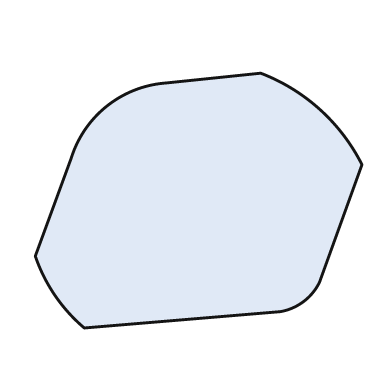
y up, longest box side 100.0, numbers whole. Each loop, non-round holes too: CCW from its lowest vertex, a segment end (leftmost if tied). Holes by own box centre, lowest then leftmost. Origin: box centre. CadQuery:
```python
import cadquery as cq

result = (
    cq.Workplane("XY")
    .moveTo(-35.0, -39.0)
    .lineTo(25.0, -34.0)
    .threePointArc((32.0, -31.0), (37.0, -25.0))
    .lineTo(50.0, 11.0)
    .threePointArc((37.0, 28.0), (19.0, 39.0))
    .lineTo(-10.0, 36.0)
    .threePointArc((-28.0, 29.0), (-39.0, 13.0))
    .lineTo(-50.0, -17.0)
    .threePointArc((-44.0, -29.0), (-35.0, -39.0))
    .close()
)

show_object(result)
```